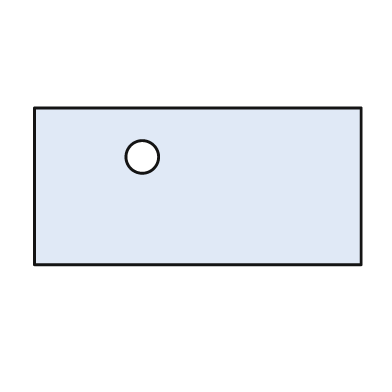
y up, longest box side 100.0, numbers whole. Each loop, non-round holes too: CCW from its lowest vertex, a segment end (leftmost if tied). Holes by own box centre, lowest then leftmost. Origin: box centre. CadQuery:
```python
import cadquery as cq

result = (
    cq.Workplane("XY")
    .moveTo(-50.0, -24.0)
    .lineTo(50.0, -24.0)
    .lineTo(50.0, 24.0)
    .lineTo(-50.0, 24.0)
    .close()
    .moveTo(-17.0, 9.0)
    .circle(5.0)
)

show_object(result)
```